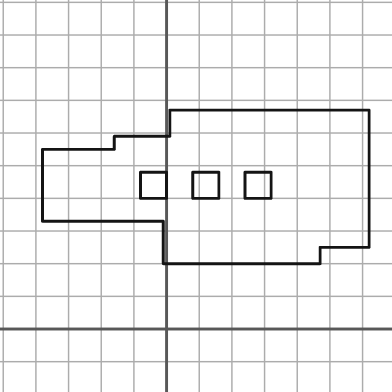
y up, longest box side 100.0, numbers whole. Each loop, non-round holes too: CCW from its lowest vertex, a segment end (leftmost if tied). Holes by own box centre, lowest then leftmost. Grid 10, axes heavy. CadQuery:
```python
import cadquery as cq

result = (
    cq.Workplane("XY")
    .moveTo(-1.0, 20.0)
    .lineTo(47.0, 20.0)
    .lineTo(47.0, 25.0)
    .lineTo(62.0, 25.0)
    .lineTo(62.0, 67.0)
    .lineTo(1.0, 67.0)
    .lineTo(1.0, 59.0)
    .lineTo(-16.0, 59.0)
    .lineTo(-16.0, 55.0)
    .lineTo(-38.0, 55.0)
    .lineTo(-38.0, 33.0)
    .lineTo(-1.0, 33.0)
    .close()
    .moveTo(-8.0, 40.0)
    .lineTo(0.0, 40.0)
    .lineTo(0.0, 48.0)
    .lineTo(-8.0, 48.0)
    .close()
    .moveTo(8.0, 40.0)
    .lineTo(16.0, 40.0)
    .lineTo(16.0, 48.0)
    .lineTo(8.0, 48.0)
    .close()
    .moveTo(24.0, 40.0)
    .lineTo(32.0, 40.0)
    .lineTo(32.0, 48.0)
    .lineTo(24.0, 48.0)
    .close()
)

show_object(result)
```